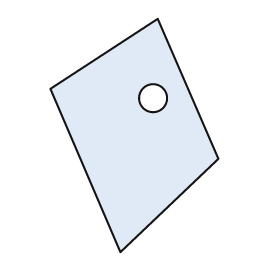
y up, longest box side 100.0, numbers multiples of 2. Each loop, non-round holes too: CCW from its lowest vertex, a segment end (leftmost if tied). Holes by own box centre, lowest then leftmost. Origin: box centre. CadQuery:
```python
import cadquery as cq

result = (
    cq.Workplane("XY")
    .moveTo(-6.0, -50.0)
    .lineTo(36.0, -10.0)
    .lineTo(10.0, 50.0)
    .lineTo(-36.0, 20.0)
    .close()
    .moveTo(8.0, 16.0)
    .circle(6.0)
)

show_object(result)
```